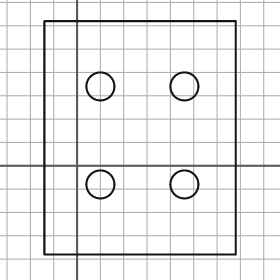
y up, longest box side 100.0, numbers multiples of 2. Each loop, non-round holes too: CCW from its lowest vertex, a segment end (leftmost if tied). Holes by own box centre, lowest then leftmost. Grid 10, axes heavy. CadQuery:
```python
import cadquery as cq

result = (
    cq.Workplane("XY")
    .moveTo(-14.0, -38.0)
    .lineTo(68.0, -38.0)
    .lineTo(68.0, 62.0)
    .lineTo(-14.0, 62.0)
    .close()
    .moveTo(10.0, -8.0)
    .circle(6.0)
    .moveTo(46.0, -8.0)
    .circle(6.0)
    .moveTo(10.0, 34.0)
    .circle(6.0)
    .moveTo(46.0, 34.0)
    .circle(6.0)
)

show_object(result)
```